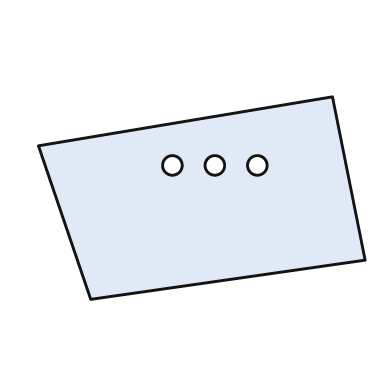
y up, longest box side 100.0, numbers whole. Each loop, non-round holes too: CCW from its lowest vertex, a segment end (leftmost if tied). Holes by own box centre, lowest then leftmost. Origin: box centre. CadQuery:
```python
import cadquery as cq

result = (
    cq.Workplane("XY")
    .moveTo(-34.0, -31.0)
    .lineTo(50.0, -19.0)
    .lineTo(40.0, 31.0)
    .lineTo(-50.0, 16.0)
    .close()
    .moveTo(-9.0, 10.0)
    .circle(3.0)
    .moveTo(4.0, 10.0)
    .circle(3.0)
    .moveTo(17.0, 10.0)
    .circle(3.0)
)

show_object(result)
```